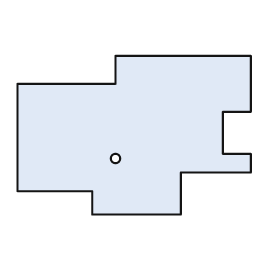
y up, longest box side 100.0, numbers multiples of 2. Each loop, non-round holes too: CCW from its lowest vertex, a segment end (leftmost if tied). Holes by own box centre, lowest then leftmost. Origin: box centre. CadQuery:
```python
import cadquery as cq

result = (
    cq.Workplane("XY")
    .moveTo(-18.0, -34.0)
    .lineTo(20.0, -34.0)
    .lineTo(20.0, -16.0)
    .lineTo(50.0, -16.0)
    .lineTo(50.0, -8.0)
    .lineTo(38.0, -8.0)
    .lineTo(38.0, 10.0)
    .lineTo(50.0, 10.0)
    .lineTo(50.0, 34.0)
    .lineTo(-8.0, 34.0)
    .lineTo(-8.0, 22.0)
    .lineTo(-50.0, 22.0)
    .lineTo(-50.0, -24.0)
    .lineTo(-18.0, -24.0)
    .close()
    .moveTo(-8.0, -10.0)
    .circle(2.0)
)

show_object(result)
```